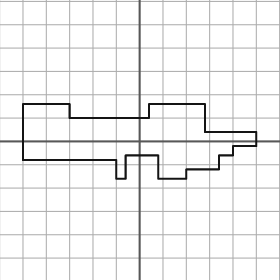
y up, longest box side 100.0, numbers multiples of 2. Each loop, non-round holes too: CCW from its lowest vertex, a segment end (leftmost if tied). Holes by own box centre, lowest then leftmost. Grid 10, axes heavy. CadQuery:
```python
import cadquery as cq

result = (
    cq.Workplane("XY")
    .moveTo(-10.0, -16.0)
    .lineTo(-6.0, -16.0)
    .lineTo(-6.0, -6.0)
    .lineTo(8.0, -6.0)
    .lineTo(8.0, -16.0)
    .lineTo(20.0, -16.0)
    .lineTo(20.0, -12.0)
    .lineTo(34.0, -12.0)
    .lineTo(34.0, -6.0)
    .lineTo(40.0, -6.0)
    .lineTo(40.0, -2.0)
    .lineTo(50.0, -2.0)
    .lineTo(50.0, 4.0)
    .lineTo(28.0, 4.0)
    .lineTo(28.0, 16.0)
    .lineTo(4.0, 16.0)
    .lineTo(4.0, 10.0)
    .lineTo(-30.0, 10.0)
    .lineTo(-30.0, 16.0)
    .lineTo(-50.0, 16.0)
    .lineTo(-50.0, -8.0)
    .lineTo(-10.0, -8.0)
    .close()
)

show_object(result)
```